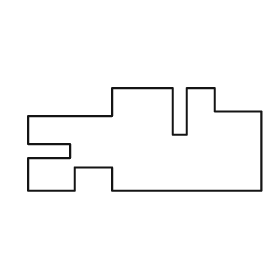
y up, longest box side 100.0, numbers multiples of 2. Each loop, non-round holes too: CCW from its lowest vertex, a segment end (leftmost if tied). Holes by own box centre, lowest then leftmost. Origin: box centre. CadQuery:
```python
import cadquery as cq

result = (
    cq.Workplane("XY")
    .moveTo(-50.0, -22.0)
    .lineTo(-30.0, -22.0)
    .lineTo(-30.0, -12.0)
    .lineTo(-14.0, -12.0)
    .lineTo(-14.0, -22.0)
    .lineTo(50.0, -22.0)
    .lineTo(50.0, 12.0)
    .lineTo(30.0, 12.0)
    .lineTo(30.0, 22.0)
    .lineTo(18.0, 22.0)
    .lineTo(18.0, 2.0)
    .lineTo(12.0, 2.0)
    .lineTo(12.0, 22.0)
    .lineTo(-14.0, 22.0)
    .lineTo(-14.0, 10.0)
    .lineTo(-50.0, 10.0)
    .lineTo(-50.0, -2.0)
    .lineTo(-32.0, -2.0)
    .lineTo(-32.0, -8.0)
    .lineTo(-50.0, -8.0)
    .close()
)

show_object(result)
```